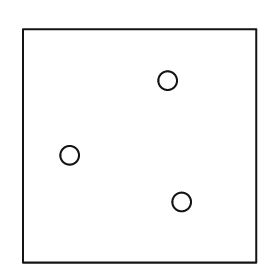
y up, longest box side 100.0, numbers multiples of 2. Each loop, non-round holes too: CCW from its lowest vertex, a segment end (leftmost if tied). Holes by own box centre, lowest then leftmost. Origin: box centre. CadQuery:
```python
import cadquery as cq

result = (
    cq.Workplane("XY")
    .moveTo(-50.0, -50.0)
    .lineTo(50.0, -50.0)
    .lineTo(50.0, 50.0)
    .lineTo(-50.0, 50.0)
    .close()
    .moveTo(18.0, -24.0)
    .circle(4.0)
    .moveTo(-30.0, -4.0)
    .circle(4.0)
    .moveTo(12.0, 28.0)
    .circle(4.0)
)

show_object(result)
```